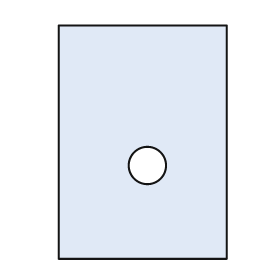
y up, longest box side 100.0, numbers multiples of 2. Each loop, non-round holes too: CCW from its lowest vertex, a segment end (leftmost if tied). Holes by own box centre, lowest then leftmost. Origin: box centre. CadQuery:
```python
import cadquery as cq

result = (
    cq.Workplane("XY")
    .moveTo(-36.0, -50.0)
    .lineTo(36.0, -50.0)
    .lineTo(36.0, 50.0)
    .lineTo(-36.0, 50.0)
    .close()
    .moveTo(2.0, -10.0)
    .circle(8.0)
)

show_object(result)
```